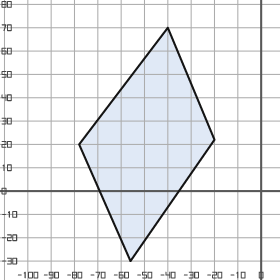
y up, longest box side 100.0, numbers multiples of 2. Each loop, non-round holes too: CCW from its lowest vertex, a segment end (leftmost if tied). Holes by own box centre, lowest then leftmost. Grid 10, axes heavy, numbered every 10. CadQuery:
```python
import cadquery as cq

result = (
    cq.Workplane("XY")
    .moveTo(-56.0, -30.0)
    .lineTo(-20.0, 22.0)
    .lineTo(-40.0, 70.0)
    .lineTo(-78.0, 20.0)
    .close()
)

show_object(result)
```